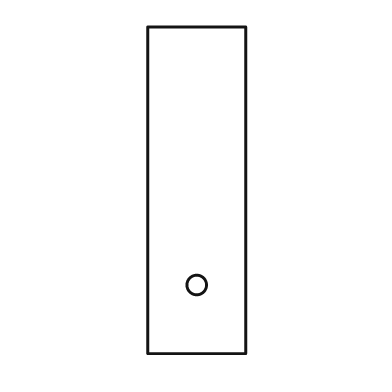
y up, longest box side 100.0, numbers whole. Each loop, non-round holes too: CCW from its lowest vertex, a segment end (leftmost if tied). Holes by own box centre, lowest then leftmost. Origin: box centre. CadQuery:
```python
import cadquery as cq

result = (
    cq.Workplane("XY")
    .moveTo(-15.0, -50.0)
    .lineTo(15.0, -50.0)
    .lineTo(15.0, 50.0)
    .lineTo(-15.0, 50.0)
    .close()
    .moveTo(0.0, -29.0)
    .circle(3.0)
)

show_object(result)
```